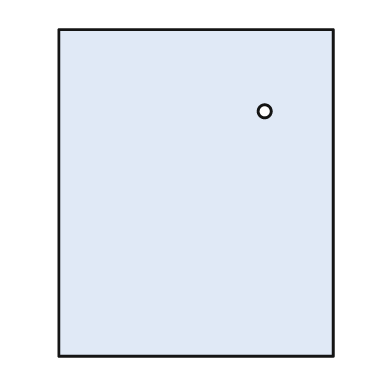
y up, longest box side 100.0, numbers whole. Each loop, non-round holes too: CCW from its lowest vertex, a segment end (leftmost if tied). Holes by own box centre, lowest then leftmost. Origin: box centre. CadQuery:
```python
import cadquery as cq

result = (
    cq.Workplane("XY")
    .moveTo(-42.0, -50.0)
    .lineTo(42.0, -50.0)
    .lineTo(42.0, 50.0)
    .lineTo(-42.0, 50.0)
    .close()
    .moveTo(21.0, 25.0)
    .circle(2.0)
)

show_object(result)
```